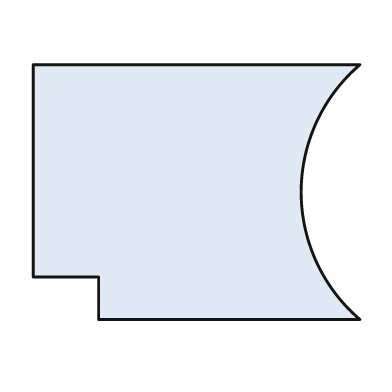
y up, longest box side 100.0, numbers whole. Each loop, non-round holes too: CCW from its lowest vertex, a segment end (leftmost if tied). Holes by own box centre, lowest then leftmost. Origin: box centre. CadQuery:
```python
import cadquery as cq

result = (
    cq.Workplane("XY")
    .moveTo(-30.0, -39.0)
    .lineTo(50.0, -39.0)
    .threePointArc((32.0, 0.0), (50.0, 39.0))
    .lineTo(-50.0, 39.0)
    .lineTo(-50.0, -26.0)
    .lineTo(-30.0, -26.0)
    .close()
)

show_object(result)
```